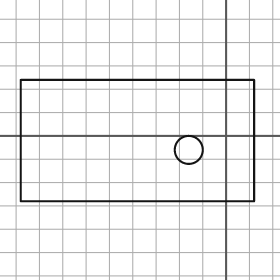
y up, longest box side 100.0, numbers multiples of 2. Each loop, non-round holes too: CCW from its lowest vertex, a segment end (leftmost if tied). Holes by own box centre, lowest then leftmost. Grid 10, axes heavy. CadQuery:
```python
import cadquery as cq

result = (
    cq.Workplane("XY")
    .moveTo(-88.0, -28.0)
    .lineTo(12.0, -28.0)
    .lineTo(12.0, 24.0)
    .lineTo(-88.0, 24.0)
    .close()
    .moveTo(-16.0, -6.0)
    .circle(6.0)
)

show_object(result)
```